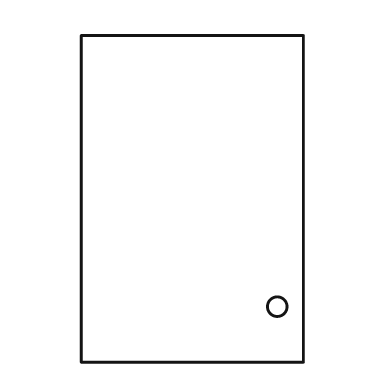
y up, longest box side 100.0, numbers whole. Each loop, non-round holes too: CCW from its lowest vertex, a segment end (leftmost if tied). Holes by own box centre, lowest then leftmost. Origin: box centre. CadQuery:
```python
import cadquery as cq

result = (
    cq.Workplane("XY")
    .moveTo(-34.0, -50.0)
    .lineTo(34.0, -50.0)
    .lineTo(34.0, 50.0)
    .lineTo(-34.0, 50.0)
    .close()
    .moveTo(26.0, -33.0)
    .circle(3.0)
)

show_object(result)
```